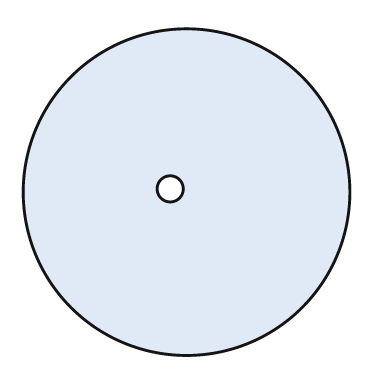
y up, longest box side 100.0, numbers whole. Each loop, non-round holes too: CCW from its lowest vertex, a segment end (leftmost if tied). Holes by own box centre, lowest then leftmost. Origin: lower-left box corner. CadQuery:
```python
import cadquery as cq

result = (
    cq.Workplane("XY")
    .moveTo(50.0, 50.0)
    .circle(50.0)
    .moveTo(45.0, 51.0)
    .circle(4.0)
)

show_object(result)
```